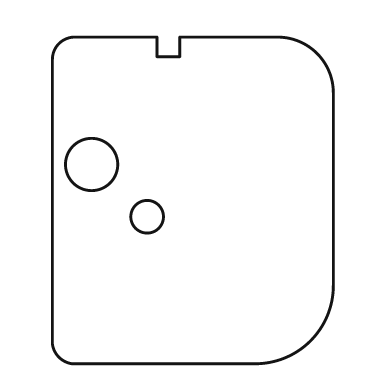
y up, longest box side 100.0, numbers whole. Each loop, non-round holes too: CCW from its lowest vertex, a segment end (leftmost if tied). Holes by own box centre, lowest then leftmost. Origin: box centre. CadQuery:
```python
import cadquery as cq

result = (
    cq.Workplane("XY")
    .moveTo(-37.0, -50.0)
    .lineTo(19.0, -50.0)
    .threePointArc((36.0, -43.0), (43.0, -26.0))
    .lineTo(43.0, 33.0)
    .threePointArc((38.0, 45.0), (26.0, 50.0))
    .lineTo(-4.0, 50.0)
    .lineTo(-4.0, 44.0)
    .lineTo(-11.0, 44.0)
    .lineTo(-11.0, 50.0)
    .lineTo(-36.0, 50.0)
    .threePointArc((-41.0, 48.0), (-43.0, 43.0))
    .lineTo(-43.0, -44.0)
    .threePointArc((-41.0, -48.0), (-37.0, -50.0))
    .close()
    .moveTo(-14.0, -5.0)
    .circle(5.0)
    .moveTo(-31.0, 11.0)
    .circle(8.0)
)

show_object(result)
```